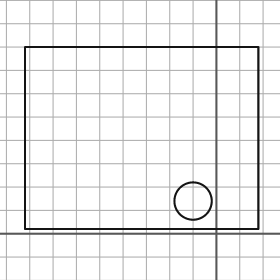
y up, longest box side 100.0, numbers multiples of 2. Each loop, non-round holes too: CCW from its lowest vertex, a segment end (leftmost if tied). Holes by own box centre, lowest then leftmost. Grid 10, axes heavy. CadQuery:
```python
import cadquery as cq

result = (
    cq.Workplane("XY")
    .moveTo(-82.0, 2.0)
    .lineTo(18.0, 2.0)
    .lineTo(18.0, 80.0)
    .lineTo(-82.0, 80.0)
    .close()
    .moveTo(-10.0, 14.0)
    .circle(8.0)
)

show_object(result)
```